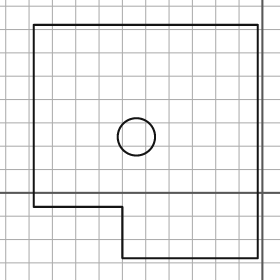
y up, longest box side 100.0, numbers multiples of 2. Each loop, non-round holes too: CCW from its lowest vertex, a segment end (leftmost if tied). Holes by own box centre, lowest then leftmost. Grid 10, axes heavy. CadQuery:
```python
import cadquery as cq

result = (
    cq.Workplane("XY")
    .moveTo(-60.0, -28.0)
    .lineTo(-2.0, -28.0)
    .lineTo(-2.0, 72.0)
    .lineTo(-98.0, 72.0)
    .lineTo(-98.0, -6.0)
    .lineTo(-60.0, -6.0)
    .close()
    .moveTo(-54.0, 24.0)
    .circle(8.0)
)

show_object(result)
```